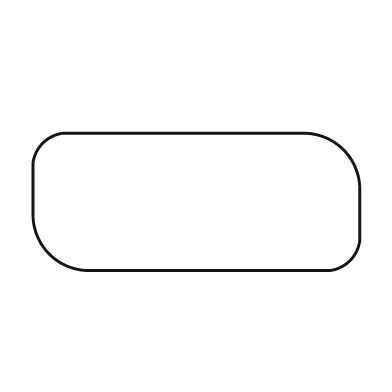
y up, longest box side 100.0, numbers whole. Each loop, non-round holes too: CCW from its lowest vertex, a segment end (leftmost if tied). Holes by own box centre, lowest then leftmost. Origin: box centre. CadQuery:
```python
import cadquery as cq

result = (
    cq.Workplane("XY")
    .moveTo(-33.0, -21.0)
    .lineTo(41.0, -21.0)
    .threePointArc((47.0, -18.0), (50.0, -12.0))
    .lineTo(50.0, 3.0)
    .threePointArc((45.0, 16.0), (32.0, 21.0))
    .lineTo(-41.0, 21.0)
    .threePointArc((-47.0, 18.0), (-50.0, 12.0))
    .lineTo(-50.0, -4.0)
    .threePointArc((-45.0, -16.0), (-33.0, -21.0))
    .close()
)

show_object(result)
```